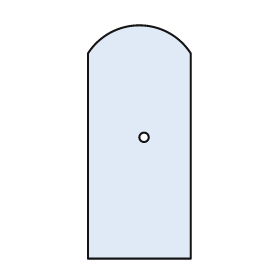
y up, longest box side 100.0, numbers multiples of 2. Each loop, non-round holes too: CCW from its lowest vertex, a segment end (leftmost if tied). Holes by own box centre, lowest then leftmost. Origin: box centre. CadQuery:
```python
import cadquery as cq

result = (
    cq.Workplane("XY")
    .moveTo(-22.0, -50.0)
    .lineTo(22.0, -50.0)
    .lineTo(22.0, 38.0)
    .threePointArc((0.0, 50.0), (-22.0, 38.0))
    .close()
    .moveTo(2.0, 2.0)
    .circle(2.0)
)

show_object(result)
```